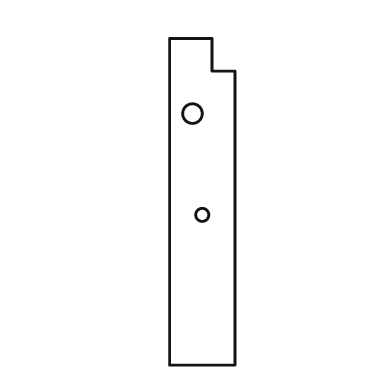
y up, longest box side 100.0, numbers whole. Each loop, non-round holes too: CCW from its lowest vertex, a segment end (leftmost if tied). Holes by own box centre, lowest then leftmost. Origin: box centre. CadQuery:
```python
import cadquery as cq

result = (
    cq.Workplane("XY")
    .moveTo(-10.0, -50.0)
    .lineTo(10.0, -50.0)
    .lineTo(10.0, 40.0)
    .lineTo(3.0, 40.0)
    .lineTo(3.0, 50.0)
    .lineTo(-10.0, 50.0)
    .close()
    .moveTo(0.0, -4.0)
    .circle(2.0)
    .moveTo(-3.0, 27.0)
    .circle(3.0)
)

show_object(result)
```